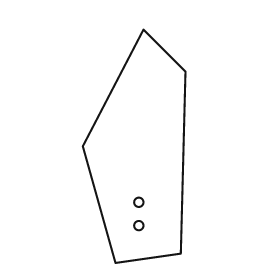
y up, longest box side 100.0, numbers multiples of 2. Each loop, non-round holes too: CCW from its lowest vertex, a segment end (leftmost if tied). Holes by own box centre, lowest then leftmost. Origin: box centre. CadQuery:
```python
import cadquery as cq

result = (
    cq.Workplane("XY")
    .moveTo(-8.0, -50.0)
    .lineTo(20.0, -46.0)
    .lineTo(22.0, 32.0)
    .lineTo(4.0, 50.0)
    .lineTo(-22.0, 0.0)
    .close()
    .moveTo(2.0, -34.0)
    .circle(2.0)
    .moveTo(2.0, -24.0)
    .circle(2.0)
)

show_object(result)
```